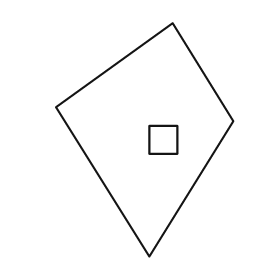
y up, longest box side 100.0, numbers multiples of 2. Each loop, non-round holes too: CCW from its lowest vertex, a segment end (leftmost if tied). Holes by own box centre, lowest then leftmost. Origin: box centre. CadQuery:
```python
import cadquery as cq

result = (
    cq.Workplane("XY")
    .moveTo(2.0, -50.0)
    .lineTo(38.0, 8.0)
    .lineTo(12.0, 50.0)
    .lineTo(-38.0, 14.0)
    .close()
    .moveTo(2.0, -6.0)
    .lineTo(14.0, -6.0)
    .lineTo(14.0, 6.0)
    .lineTo(2.0, 6.0)
    .close()
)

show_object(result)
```